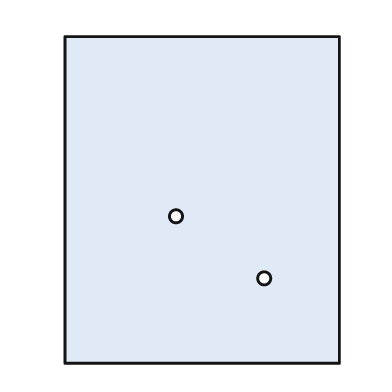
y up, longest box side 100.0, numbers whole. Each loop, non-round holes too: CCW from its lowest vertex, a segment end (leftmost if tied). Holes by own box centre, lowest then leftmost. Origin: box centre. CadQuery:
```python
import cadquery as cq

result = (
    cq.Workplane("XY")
    .moveTo(-42.0, -50.0)
    .lineTo(42.0, -50.0)
    .lineTo(42.0, 50.0)
    .lineTo(-42.0, 50.0)
    .close()
    .moveTo(19.0, -24.0)
    .circle(2.0)
    .moveTo(-8.0, -5.0)
    .circle(2.0)
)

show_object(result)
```